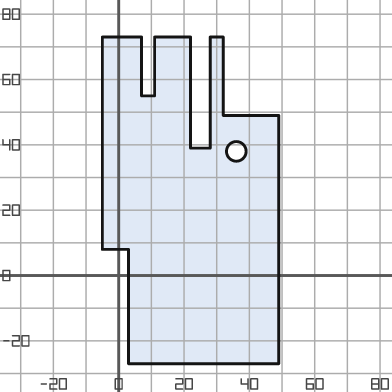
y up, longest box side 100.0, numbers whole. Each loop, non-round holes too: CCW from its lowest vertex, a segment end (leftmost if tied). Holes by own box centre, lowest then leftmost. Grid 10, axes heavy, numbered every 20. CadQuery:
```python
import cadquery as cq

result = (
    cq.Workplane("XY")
    .moveTo(3.0, -27.0)
    .lineTo(49.0, -27.0)
    .lineTo(49.0, 49.0)
    .lineTo(32.0, 49.0)
    .lineTo(32.0, 73.0)
    .lineTo(28.0, 73.0)
    .lineTo(28.0, 39.0)
    .lineTo(22.0, 39.0)
    .lineTo(22.0, 73.0)
    .lineTo(11.0, 73.0)
    .lineTo(11.0, 55.0)
    .lineTo(7.0, 55.0)
    .lineTo(7.0, 73.0)
    .lineTo(-5.0, 73.0)
    .lineTo(-5.0, 8.0)
    .lineTo(3.0, 8.0)
    .close()
    .moveTo(36.0, 38.0)
    .circle(3.0)
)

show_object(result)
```